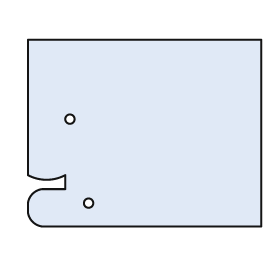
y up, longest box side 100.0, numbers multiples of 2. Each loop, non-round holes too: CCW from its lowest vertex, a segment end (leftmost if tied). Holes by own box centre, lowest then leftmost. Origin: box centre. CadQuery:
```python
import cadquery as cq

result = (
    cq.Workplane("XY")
    .moveTo(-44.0, -40.0)
    .lineTo(50.0, -40.0)
    .lineTo(50.0, 40.0)
    .lineTo(-50.0, 40.0)
    .lineTo(-50.0, -18.0)
    .threePointArc((-42.0, -20.0), (-34.0, -18.0))
    .lineTo(-34.0, -24.0)
    .lineTo(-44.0, -24.0)
    .threePointArc((-48.0, -26.0), (-50.0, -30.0))
    .lineTo(-50.0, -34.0)
    .threePointArc((-48.0, -38.0), (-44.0, -40.0))
    .close()
    .moveTo(-24.0, -30.0)
    .circle(2.0)
    .moveTo(-32.0, 6.0)
    .circle(2.0)
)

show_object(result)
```